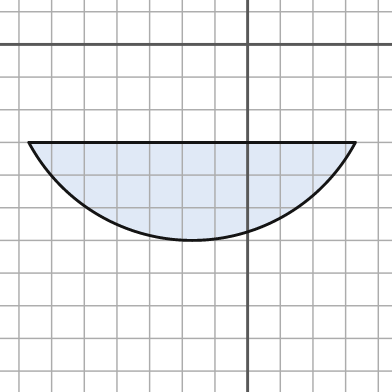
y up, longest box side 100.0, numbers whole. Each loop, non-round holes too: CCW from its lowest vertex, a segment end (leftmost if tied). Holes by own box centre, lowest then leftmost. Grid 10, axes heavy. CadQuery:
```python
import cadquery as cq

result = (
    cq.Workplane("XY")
    .moveTo(-67.0, -30.0)
    .threePointArc((-17.0, -60.0), (33.0, -30.0))
    .close()
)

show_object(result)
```